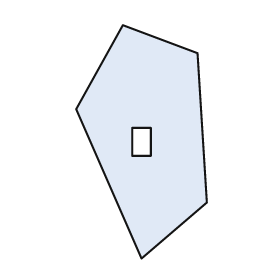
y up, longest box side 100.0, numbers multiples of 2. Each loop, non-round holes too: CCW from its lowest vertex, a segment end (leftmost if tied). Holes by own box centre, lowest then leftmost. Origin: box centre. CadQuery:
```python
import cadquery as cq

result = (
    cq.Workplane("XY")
    .moveTo(0.0, -50.0)
    .lineTo(28.0, -26.0)
    .lineTo(24.0, 38.0)
    .lineTo(-8.0, 50.0)
    .lineTo(-28.0, 14.0)
    .close()
    .moveTo(-4.0, -6.0)
    .lineTo(4.0, -6.0)
    .lineTo(4.0, 6.0)
    .lineTo(-4.0, 6.0)
    .close()
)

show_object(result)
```